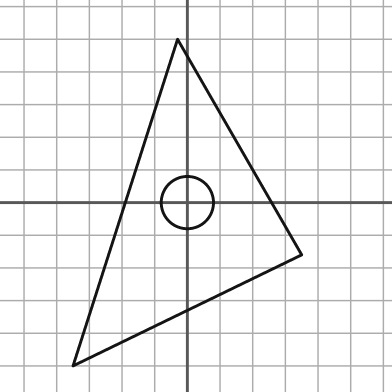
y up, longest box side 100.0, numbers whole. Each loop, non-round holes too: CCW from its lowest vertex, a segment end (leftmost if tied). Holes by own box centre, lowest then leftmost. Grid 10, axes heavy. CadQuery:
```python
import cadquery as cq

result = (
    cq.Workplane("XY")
    .moveTo(-35.0, -50.0)
    .lineTo(35.0, -16.0)
    .lineTo(-3.0, 50.0)
    .close()
    .moveTo(0.0, 0.0)
    .circle(8.0)
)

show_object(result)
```